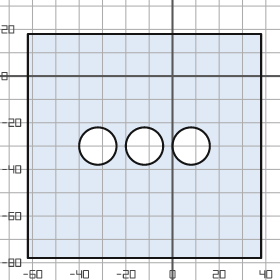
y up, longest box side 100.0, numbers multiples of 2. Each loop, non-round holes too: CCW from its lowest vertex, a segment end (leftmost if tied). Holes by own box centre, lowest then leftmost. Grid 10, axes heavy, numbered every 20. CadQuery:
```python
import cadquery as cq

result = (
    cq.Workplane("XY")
    .moveTo(-62.0, -78.0)
    .lineTo(38.0, -78.0)
    .lineTo(38.0, 18.0)
    .lineTo(-62.0, 18.0)
    .close()
    .moveTo(-32.0, -30.0)
    .circle(8.0)
    .moveTo(-12.0, -30.0)
    .circle(8.0)
    .moveTo(8.0, -30.0)
    .circle(8.0)
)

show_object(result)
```